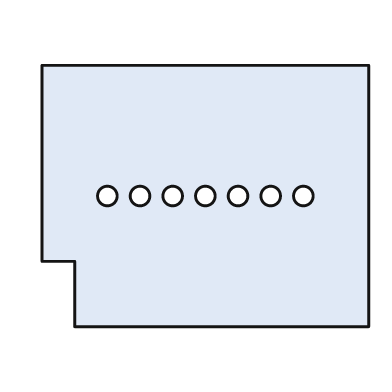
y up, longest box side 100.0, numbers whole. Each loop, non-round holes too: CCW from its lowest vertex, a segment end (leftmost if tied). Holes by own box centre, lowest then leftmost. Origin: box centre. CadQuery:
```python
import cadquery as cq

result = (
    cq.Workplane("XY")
    .moveTo(-40.0, -40.0)
    .lineTo(50.0, -40.0)
    .lineTo(50.0, 40.0)
    .lineTo(-50.0, 40.0)
    .lineTo(-50.0, -20.0)
    .lineTo(-40.0, -20.0)
    .close()
    .moveTo(-30.0, 0.0)
    .circle(3.0)
    .moveTo(-20.0, 0.0)
    .circle(3.0)
    .moveTo(-10.0, 0.0)
    .circle(3.0)
    .moveTo(0.0, 0.0)
    .circle(3.0)
    .moveTo(10.0, 0.0)
    .circle(3.0)
    .moveTo(20.0, 0.0)
    .circle(3.0)
    .moveTo(30.0, 0.0)
    .circle(3.0)
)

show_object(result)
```